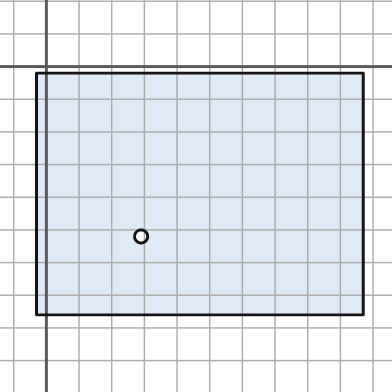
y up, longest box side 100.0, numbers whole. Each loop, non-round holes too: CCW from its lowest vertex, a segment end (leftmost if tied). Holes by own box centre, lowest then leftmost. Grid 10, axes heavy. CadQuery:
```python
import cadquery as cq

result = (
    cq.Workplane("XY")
    .moveTo(-3.0, -76.0)
    .lineTo(97.0, -76.0)
    .lineTo(97.0, -2.0)
    .lineTo(-3.0, -2.0)
    .close()
    .moveTo(29.0, -52.0)
    .circle(2.0)
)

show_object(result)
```